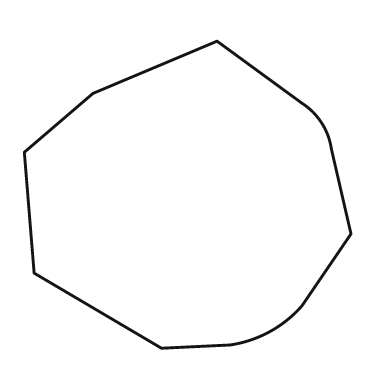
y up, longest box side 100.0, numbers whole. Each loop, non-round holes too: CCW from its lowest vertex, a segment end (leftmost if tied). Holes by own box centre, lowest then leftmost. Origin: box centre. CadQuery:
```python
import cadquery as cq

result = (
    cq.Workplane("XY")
    .moveTo(-8.0, -47.0)
    .lineTo(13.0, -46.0)
    .threePointArc((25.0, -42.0), (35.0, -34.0))
    .lineTo(50.0, -12.0)
    .lineTo(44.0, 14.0)
    .threePointArc((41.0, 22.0), (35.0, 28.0))
    .lineTo(9.0, 47.0)
    .lineTo(-29.0, 31.0)
    .lineTo(-50.0, 13.0)
    .lineTo(-47.0, -24.0)
    .close()
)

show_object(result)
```